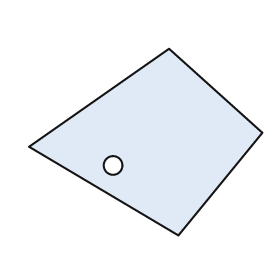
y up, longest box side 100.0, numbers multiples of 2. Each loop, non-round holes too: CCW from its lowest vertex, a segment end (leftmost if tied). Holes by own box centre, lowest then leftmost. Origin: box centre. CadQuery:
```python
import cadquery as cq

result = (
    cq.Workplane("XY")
    .moveTo(14.0, -40.0)
    .lineTo(50.0, 4.0)
    .lineTo(10.0, 40.0)
    .lineTo(-50.0, -2.0)
    .close()
    .moveTo(-14.0, -10.0)
    .circle(4.0)
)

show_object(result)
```